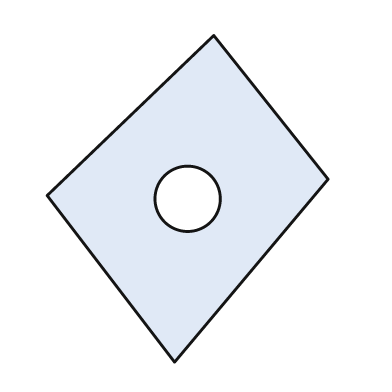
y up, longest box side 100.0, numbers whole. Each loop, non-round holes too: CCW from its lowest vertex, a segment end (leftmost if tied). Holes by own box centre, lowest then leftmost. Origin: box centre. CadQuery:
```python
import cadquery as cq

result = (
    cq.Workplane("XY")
    .moveTo(-4.0, -50.0)
    .lineTo(43.0, 6.0)
    .lineTo(8.0, 50.0)
    .lineTo(-43.0, 1.0)
    .close()
    .moveTo(0.0, 0.0)
    .circle(10.0)
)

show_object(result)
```